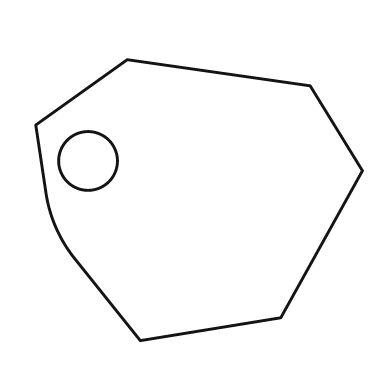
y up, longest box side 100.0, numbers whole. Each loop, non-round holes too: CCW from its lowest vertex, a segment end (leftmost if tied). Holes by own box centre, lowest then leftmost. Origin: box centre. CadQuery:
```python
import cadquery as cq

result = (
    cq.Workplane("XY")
    .moveTo(-18.0, -43.0)
    .lineTo(25.0, -36.0)
    .lineTo(50.0, 9.0)
    .lineTo(34.0, 35.0)
    .lineTo(-22.0, 43.0)
    .lineTo(-50.0, 23.0)
    .lineTo(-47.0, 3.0)
    .threePointArc((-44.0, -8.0), (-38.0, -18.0))
    .close()
    .moveTo(-34.0, 12.0)
    .circle(9.0)
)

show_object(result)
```